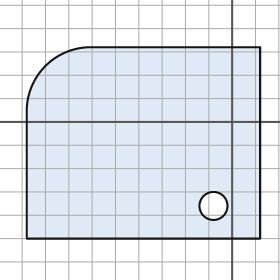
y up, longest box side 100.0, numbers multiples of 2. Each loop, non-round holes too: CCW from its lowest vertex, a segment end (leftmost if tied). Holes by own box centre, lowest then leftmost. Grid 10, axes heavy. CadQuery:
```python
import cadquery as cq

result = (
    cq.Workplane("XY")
    .moveTo(-88.0, -50.0)
    .lineTo(12.0, -50.0)
    .lineTo(12.0, 32.0)
    .lineTo(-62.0, 32.0)
    .threePointArc((-80.0, 24.0), (-88.0, 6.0))
    .close()
    .moveTo(-8.0, -36.0)
    .circle(6.0)
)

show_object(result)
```